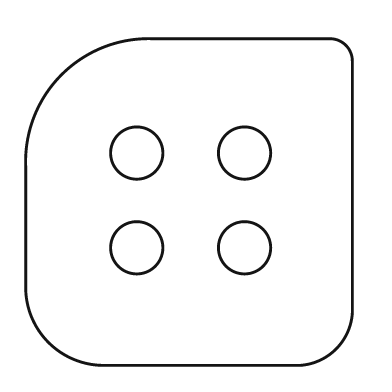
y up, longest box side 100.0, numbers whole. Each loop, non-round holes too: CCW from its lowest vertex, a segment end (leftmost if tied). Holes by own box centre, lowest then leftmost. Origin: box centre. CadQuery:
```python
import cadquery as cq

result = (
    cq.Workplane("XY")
    .moveTo(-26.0, -50.0)
    .lineTo(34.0, -50.0)
    .threePointArc((45.0, -45.0), (50.0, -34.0))
    .lineTo(50.0, 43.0)
    .threePointArc((48.0, 48.0), (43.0, 50.0))
    .lineTo(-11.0, 50.0)
    .threePointArc((-39.0, 39.0), (-50.0, 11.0))
    .lineTo(-50.0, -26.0)
    .threePointArc((-43.0, -43.0), (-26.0, -50.0))
    .close()
    .moveTo(-16.0, -14.0)
    .circle(8.0)
    .moveTo(17.0, -14.0)
    .circle(8.0)
    .moveTo(-16.0, 15.0)
    .circle(8.0)
    .moveTo(17.0, 15.0)
    .circle(8.0)
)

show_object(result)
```